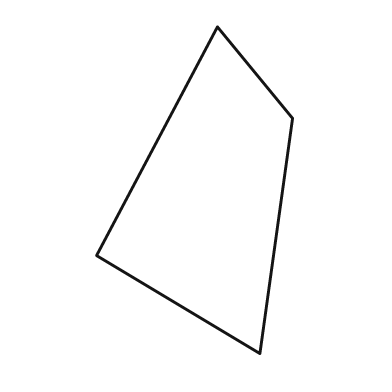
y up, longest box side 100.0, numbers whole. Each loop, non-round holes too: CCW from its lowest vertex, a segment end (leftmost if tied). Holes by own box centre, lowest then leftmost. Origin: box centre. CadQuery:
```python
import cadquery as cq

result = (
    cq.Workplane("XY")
    .moveTo(20.0, -50.0)
    .lineTo(30.0, 22.0)
    .lineTo(7.0, 50.0)
    .lineTo(-30.0, -20.0)
    .close()
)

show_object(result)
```